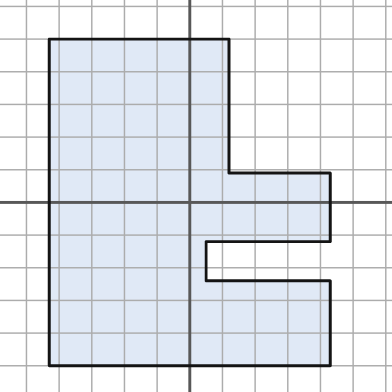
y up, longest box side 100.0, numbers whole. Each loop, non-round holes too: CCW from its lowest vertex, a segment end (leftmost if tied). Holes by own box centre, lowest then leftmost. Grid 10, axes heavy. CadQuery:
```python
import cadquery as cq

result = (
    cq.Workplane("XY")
    .moveTo(-43.0, -50.0)
    .lineTo(43.0, -50.0)
    .lineTo(43.0, -24.0)
    .lineTo(5.0, -24.0)
    .lineTo(5.0, -12.0)
    .lineTo(43.0, -12.0)
    .lineTo(43.0, 9.0)
    .lineTo(12.0, 9.0)
    .lineTo(12.0, 50.0)
    .lineTo(-43.0, 50.0)
    .close()
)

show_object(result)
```